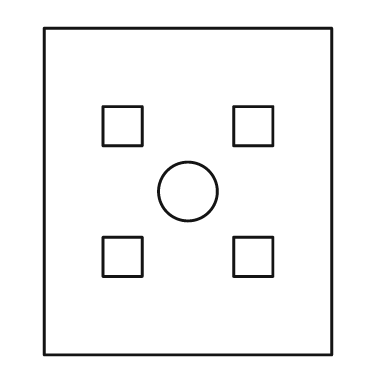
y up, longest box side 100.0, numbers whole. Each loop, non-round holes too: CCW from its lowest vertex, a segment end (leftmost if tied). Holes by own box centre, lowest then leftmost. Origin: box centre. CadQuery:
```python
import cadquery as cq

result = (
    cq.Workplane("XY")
    .moveTo(-44.0, -50.0)
    .lineTo(44.0, -50.0)
    .lineTo(44.0, 50.0)
    .lineTo(-44.0, 50.0)
    .close()
    .moveTo(-26.0, -26.0)
    .lineTo(-14.0, -26.0)
    .lineTo(-14.0, -14.0)
    .lineTo(-26.0, -14.0)
    .close()
    .moveTo(14.0, -26.0)
    .lineTo(26.0, -26.0)
    .lineTo(26.0, -14.0)
    .lineTo(14.0, -14.0)
    .close()
    .moveTo(0.0, 0.0)
    .circle(9.0)
    .moveTo(-26.0, 14.0)
    .lineTo(-14.0, 14.0)
    .lineTo(-14.0, 26.0)
    .lineTo(-26.0, 26.0)
    .close()
    .moveTo(14.0, 14.0)
    .lineTo(26.0, 14.0)
    .lineTo(26.0, 26.0)
    .lineTo(14.0, 26.0)
    .close()
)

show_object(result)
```